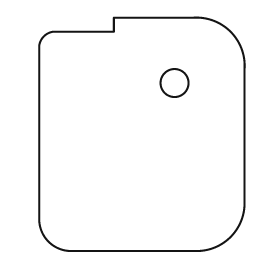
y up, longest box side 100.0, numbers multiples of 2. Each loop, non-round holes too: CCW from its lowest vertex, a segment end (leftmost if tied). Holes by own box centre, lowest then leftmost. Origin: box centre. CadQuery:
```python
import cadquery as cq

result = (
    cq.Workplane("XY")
    .moveTo(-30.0, -50.0)
    .lineTo(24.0, -50.0)
    .threePointArc((38.0, -44.0), (44.0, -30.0))
    .lineTo(44.0, 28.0)
    .threePointArc((38.0, 44.0), (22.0, 50.0))
    .lineTo(-12.0, 50.0)
    .lineTo(-12.0, 44.0)
    .lineTo(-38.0, 44.0)
    .threePointArc((-42.0, 42.0), (-44.0, 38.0))
    .lineTo(-44.0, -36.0)
    .threePointArc((-40.0, -46.0), (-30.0, -50.0))
    .close()
    .moveTo(14.0, 22.0)
    .circle(6.0)
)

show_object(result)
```